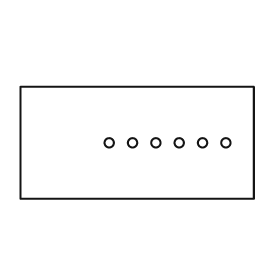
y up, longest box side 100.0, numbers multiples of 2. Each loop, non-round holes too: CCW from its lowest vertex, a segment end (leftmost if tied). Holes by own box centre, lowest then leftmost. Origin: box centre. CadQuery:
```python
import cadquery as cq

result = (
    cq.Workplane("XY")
    .moveTo(-50.0, -24.0)
    .lineTo(50.0, -24.0)
    .lineTo(50.0, 24.0)
    .lineTo(-50.0, 24.0)
    .close()
    .moveTo(-12.0, 0.0)
    .circle(2.0)
    .moveTo(-2.0, 0.0)
    .circle(2.0)
    .moveTo(8.0, 0.0)
    .circle(2.0)
    .moveTo(18.0, 0.0)
    .circle(2.0)
    .moveTo(28.0, 0.0)
    .circle(2.0)
    .moveTo(38.0, 0.0)
    .circle(2.0)
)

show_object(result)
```